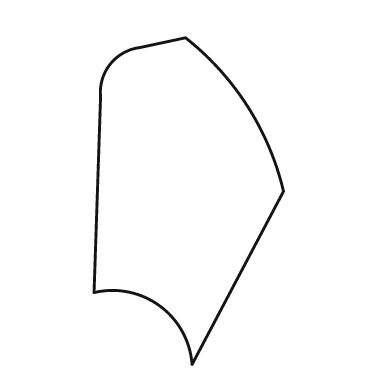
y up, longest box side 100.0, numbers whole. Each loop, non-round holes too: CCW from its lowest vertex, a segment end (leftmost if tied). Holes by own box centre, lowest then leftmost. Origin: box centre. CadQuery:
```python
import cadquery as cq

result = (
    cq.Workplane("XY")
    .moveTo(1.0, -50.0)
    .lineTo(29.0, 3.0)
    .threePointArc((18.0, 29.0), (-1.0, 50.0))
    .lineTo(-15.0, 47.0)
    .threePointArc((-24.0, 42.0), (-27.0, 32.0))
    .lineTo(-29.0, -28.0)
    .threePointArc((-9.0, -32.0), (1.0, -50.0))
    .close()
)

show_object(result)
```